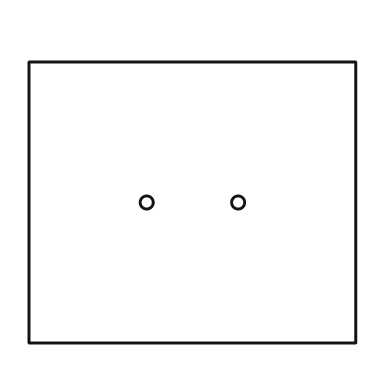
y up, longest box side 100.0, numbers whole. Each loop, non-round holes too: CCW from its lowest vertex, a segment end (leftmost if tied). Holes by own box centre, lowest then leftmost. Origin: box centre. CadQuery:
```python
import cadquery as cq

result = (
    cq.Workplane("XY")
    .moveTo(-50.0, -43.0)
    .lineTo(50.0, -43.0)
    .lineTo(50.0, 43.0)
    .lineTo(-50.0, 43.0)
    .close()
    .moveTo(-14.0, 0.0)
    .circle(2.0)
    .moveTo(14.0, 0.0)
    .circle(2.0)
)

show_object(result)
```